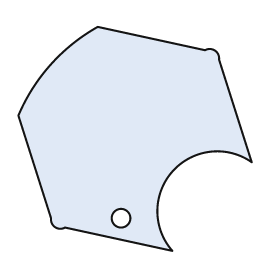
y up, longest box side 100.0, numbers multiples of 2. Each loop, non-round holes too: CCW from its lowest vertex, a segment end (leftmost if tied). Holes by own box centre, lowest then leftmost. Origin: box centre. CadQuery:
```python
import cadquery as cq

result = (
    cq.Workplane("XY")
    .moveTo(16.0, -48.0)
    .threePointArc((16.0, -14.0), (50.0, -10.0))
    .lineTo(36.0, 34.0)
    .threePointArc((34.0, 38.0), (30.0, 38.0))
    .lineTo(-16.0, 48.0)
    .threePointArc((-36.0, 32.0), (-50.0, 10.0))
    .lineTo(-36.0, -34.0)
    .threePointArc((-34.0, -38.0), (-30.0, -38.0))
    .close()
    .moveTo(-6.0, -34.0)
    .circle(4.0)
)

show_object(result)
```